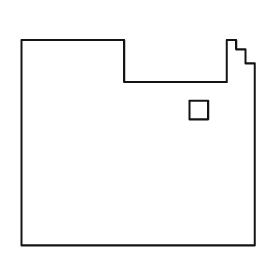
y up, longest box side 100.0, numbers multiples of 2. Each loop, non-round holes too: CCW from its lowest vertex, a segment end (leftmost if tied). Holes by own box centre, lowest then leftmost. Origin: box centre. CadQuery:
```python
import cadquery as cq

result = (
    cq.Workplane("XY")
    .moveTo(-50.0, -44.0)
    .lineTo(50.0, -44.0)
    .lineTo(50.0, 34.0)
    .lineTo(46.0, 34.0)
    .lineTo(46.0, 40.0)
    .lineTo(42.0, 40.0)
    .lineTo(42.0, 44.0)
    .lineTo(38.0, 44.0)
    .lineTo(38.0, 26.0)
    .lineTo(-6.0, 26.0)
    .lineTo(-6.0, 44.0)
    .lineTo(-50.0, 44.0)
    .close()
    .moveTo(22.0, 10.0)
    .lineTo(30.0, 10.0)
    .lineTo(30.0, 18.0)
    .lineTo(22.0, 18.0)
    .close()
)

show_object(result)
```